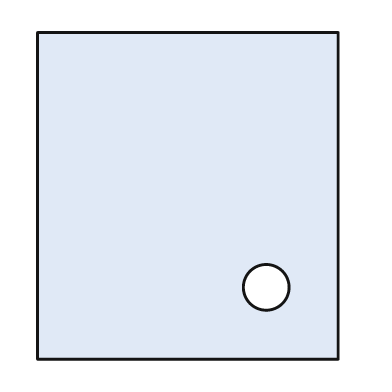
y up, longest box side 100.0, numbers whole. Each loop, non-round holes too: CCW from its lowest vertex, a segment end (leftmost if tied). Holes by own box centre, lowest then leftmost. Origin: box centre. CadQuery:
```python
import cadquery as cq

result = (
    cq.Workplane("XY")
    .moveTo(-46.0, -50.0)
    .lineTo(46.0, -50.0)
    .lineTo(46.0, 50.0)
    .lineTo(-46.0, 50.0)
    .close()
    .moveTo(24.0, -28.0)
    .circle(7.0)
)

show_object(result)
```